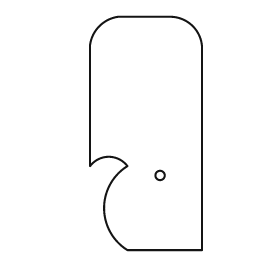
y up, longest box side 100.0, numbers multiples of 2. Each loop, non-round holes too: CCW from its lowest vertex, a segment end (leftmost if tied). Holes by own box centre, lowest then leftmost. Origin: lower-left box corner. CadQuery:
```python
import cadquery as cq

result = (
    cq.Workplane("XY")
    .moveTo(16.0, 0.0)
    .lineTo(48.0, 0.0)
    .lineTo(48.0, 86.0)
    .threePointArc((44.0, 96.0), (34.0, 100.0))
    .lineTo(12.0, 100.0)
    .threePointArc((4.0, 96.0), (0.0, 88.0))
    .lineTo(0.0, 36.0)
    .threePointArc((8.0, 40.0), (16.0, 36.0))
    .threePointArc((6.0, 18.0), (16.0, 0.0))
    .close()
    .moveTo(30.0, 32.0)
    .circle(2.0)
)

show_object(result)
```